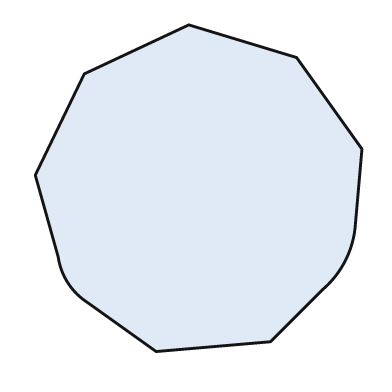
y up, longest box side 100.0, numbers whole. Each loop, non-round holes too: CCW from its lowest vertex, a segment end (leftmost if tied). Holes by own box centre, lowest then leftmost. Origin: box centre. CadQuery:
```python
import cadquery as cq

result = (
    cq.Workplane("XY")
    .moveTo(-13.0, -50.0)
    .lineTo(22.0, -47.0)
    .lineTo(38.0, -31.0)
    .threePointArc((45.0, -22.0), (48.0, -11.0))
    .lineTo(50.0, 12.0)
    .lineTo(30.0, 40.0)
    .lineTo(-3.0, 50.0)
    .lineTo(-35.0, 35.0)
    .lineTo(-50.0, 4.0)
    .lineTo(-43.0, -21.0)
    .threePointArc((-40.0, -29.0), (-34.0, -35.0))
    .close()
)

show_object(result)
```